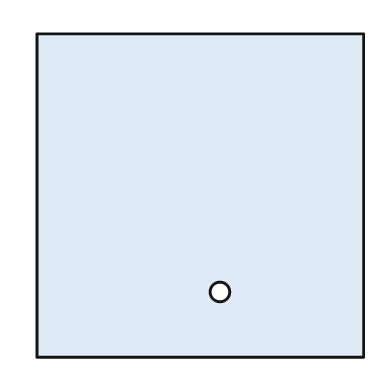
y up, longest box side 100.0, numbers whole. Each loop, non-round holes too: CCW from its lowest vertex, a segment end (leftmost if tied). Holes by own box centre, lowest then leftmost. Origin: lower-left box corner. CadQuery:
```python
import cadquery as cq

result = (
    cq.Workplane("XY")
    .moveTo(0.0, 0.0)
    .lineTo(100.0, 0.0)
    .lineTo(100.0, 99.0)
    .lineTo(0.0, 99.0)
    .close()
    .moveTo(56.0, 20.0)
    .circle(3.0)
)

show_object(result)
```